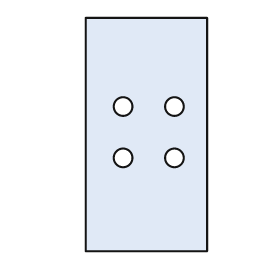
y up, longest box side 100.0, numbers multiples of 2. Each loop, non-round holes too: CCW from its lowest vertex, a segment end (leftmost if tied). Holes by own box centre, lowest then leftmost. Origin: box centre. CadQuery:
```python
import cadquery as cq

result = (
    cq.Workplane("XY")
    .moveTo(-26.0, -50.0)
    .lineTo(26.0, -50.0)
    .lineTo(26.0, 50.0)
    .lineTo(-26.0, 50.0)
    .close()
    .moveTo(-10.0, -10.0)
    .circle(4.0)
    .moveTo(12.0, -10.0)
    .circle(4.0)
    .moveTo(-10.0, 12.0)
    .circle(4.0)
    .moveTo(12.0, 12.0)
    .circle(4.0)
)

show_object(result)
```